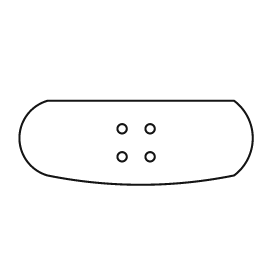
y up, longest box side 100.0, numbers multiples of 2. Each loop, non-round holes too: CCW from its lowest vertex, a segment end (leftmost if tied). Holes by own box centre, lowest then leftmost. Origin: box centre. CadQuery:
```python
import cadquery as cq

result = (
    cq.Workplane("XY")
    .moveTo(-38.0, -14.0)
    .threePointArc((2.0, -18.0), (42.0, -14.0))
    .threePointArc((50.0, 2.0), (42.0, 18.0))
    .lineTo(-38.0, 18.0)
    .threePointArc((-50.0, 2.0), (-38.0, -14.0))
    .close()
    .moveTo(-6.0, -6.0)
    .circle(2.0)
    .moveTo(6.0, -6.0)
    .circle(2.0)
    .moveTo(-6.0, 6.0)
    .circle(2.0)
    .moveTo(6.0, 6.0)
    .circle(2.0)
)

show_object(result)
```